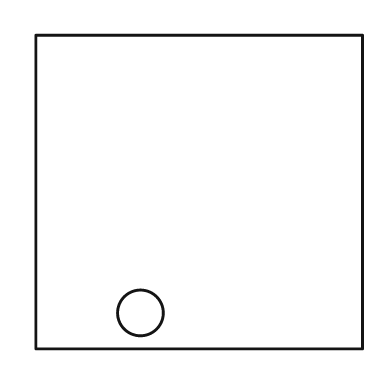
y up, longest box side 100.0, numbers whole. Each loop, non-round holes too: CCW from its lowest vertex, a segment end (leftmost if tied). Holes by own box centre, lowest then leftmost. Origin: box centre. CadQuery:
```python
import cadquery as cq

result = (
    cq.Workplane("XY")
    .moveTo(-50.0, -48.0)
    .lineTo(50.0, -48.0)
    .lineTo(50.0, 48.0)
    .lineTo(-50.0, 48.0)
    .close()
    .moveTo(-18.0, -37.0)
    .circle(7.0)
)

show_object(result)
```